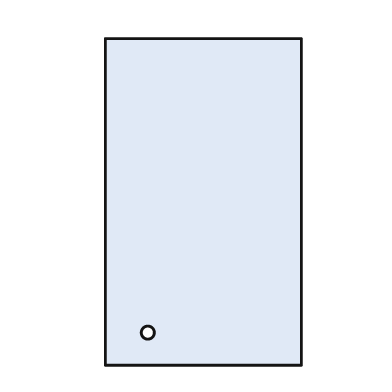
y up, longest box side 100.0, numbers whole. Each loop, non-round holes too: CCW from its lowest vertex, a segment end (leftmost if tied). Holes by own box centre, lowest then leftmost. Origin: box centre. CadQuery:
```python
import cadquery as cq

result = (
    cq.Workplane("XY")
    .moveTo(-30.0, -50.0)
    .lineTo(30.0, -50.0)
    .lineTo(30.0, 50.0)
    .lineTo(-30.0, 50.0)
    .close()
    .moveTo(-17.0, -40.0)
    .circle(2.0)
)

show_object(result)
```